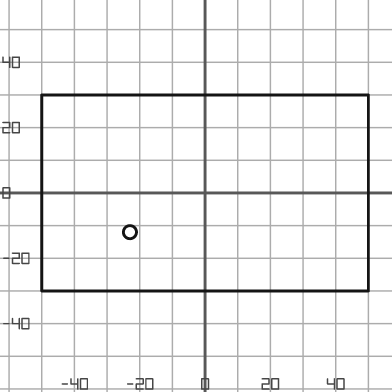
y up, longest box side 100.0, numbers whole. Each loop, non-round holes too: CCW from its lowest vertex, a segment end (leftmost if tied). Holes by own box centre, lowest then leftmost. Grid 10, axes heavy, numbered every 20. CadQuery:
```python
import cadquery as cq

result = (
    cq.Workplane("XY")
    .moveTo(-50.0, -30.0)
    .lineTo(50.0, -30.0)
    .lineTo(50.0, 30.0)
    .lineTo(-50.0, 30.0)
    .close()
    .moveTo(-23.0, -12.0)
    .circle(2.0)
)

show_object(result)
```